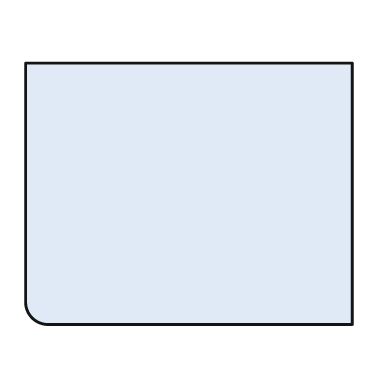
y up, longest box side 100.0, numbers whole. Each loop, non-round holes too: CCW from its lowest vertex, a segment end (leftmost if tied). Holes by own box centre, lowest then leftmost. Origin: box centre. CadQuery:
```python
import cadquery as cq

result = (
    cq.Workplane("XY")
    .moveTo(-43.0, -40.0)
    .lineTo(50.0, -40.0)
    .lineTo(50.0, 40.0)
    .lineTo(-50.0, 40.0)
    .lineTo(-50.0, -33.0)
    .threePointArc((-48.0, -38.0), (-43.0, -40.0))
    .close()
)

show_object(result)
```